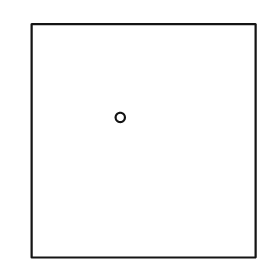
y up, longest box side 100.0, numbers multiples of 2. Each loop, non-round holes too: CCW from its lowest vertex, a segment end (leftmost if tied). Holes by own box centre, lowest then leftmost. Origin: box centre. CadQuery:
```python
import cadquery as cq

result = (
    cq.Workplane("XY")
    .moveTo(-48.0, -50.0)
    .lineTo(48.0, -50.0)
    .lineTo(48.0, 50.0)
    .lineTo(-48.0, 50.0)
    .close()
    .moveTo(-10.0, 10.0)
    .circle(2.0)
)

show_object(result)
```